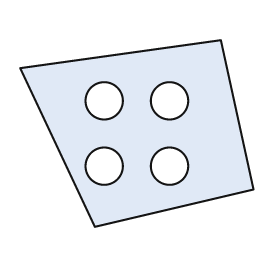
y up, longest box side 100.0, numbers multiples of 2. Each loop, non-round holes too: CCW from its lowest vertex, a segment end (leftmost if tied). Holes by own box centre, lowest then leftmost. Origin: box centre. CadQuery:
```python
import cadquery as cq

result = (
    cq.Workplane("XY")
    .moveTo(-18.0, -40.0)
    .lineTo(50.0, -24.0)
    .lineTo(36.0, 40.0)
    .lineTo(-50.0, 28.0)
    .close()
    .moveTo(-14.0, -14.0)
    .circle(8.0)
    .moveTo(14.0, -14.0)
    .circle(8.0)
    .moveTo(-14.0, 14.0)
    .circle(8.0)
    .moveTo(14.0, 14.0)
    .circle(8.0)
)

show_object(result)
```